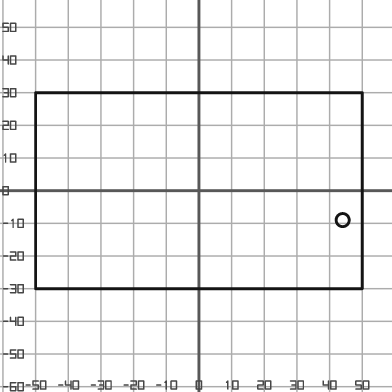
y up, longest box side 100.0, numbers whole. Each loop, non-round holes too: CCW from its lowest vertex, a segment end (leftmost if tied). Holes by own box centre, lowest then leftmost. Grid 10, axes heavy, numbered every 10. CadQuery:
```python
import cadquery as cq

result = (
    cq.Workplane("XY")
    .moveTo(-50.0, -30.0)
    .lineTo(50.0, -30.0)
    .lineTo(50.0, 30.0)
    .lineTo(-50.0, 30.0)
    .close()
    .moveTo(44.0, -9.0)
    .circle(2.0)
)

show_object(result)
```